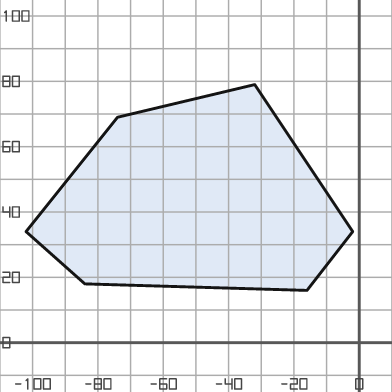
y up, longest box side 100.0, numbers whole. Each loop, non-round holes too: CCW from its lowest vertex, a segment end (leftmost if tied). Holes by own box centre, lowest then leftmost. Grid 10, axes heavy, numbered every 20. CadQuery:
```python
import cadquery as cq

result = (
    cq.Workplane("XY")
    .moveTo(-16.0, 16.0)
    .lineTo(-2.0, 34.0)
    .lineTo(-32.0, 79.0)
    .lineTo(-74.0, 69.0)
    .lineTo(-102.0, 34.0)
    .lineTo(-84.0, 18.0)
    .close()
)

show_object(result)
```